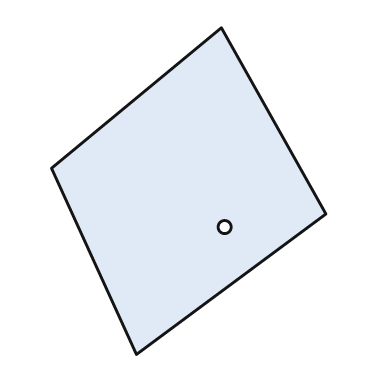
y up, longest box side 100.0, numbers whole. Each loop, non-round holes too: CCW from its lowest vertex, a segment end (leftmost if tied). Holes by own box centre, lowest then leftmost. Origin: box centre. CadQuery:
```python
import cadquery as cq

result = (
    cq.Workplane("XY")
    .moveTo(-16.0, -50.0)
    .lineTo(42.0, -7.0)
    .lineTo(10.0, 50.0)
    .lineTo(-42.0, 7.0)
    .close()
    .moveTo(11.0, -11.0)
    .circle(2.0)
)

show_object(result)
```